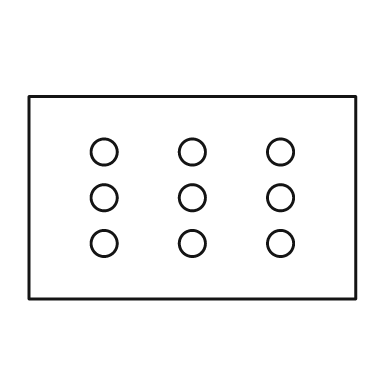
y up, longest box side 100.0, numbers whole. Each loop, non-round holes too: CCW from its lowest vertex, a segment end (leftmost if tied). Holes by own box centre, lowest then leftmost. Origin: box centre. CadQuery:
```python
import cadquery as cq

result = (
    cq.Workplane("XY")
    .moveTo(-50.0, -31.0)
    .lineTo(50.0, -31.0)
    .lineTo(50.0, 31.0)
    .lineTo(-50.0, 31.0)
    .close()
    .moveTo(-27.0, -14.0)
    .circle(4.0)
    .moveTo(0.0, -14.0)
    .circle(4.0)
    .moveTo(27.0, -14.0)
    .circle(4.0)
    .moveTo(-27.0, 0.0)
    .circle(4.0)
    .moveTo(0.0, 0.0)
    .circle(4.0)
    .moveTo(27.0, 0.0)
    .circle(4.0)
    .moveTo(-27.0, 14.0)
    .circle(4.0)
    .moveTo(0.0, 14.0)
    .circle(4.0)
    .moveTo(27.0, 14.0)
    .circle(4.0)
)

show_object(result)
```